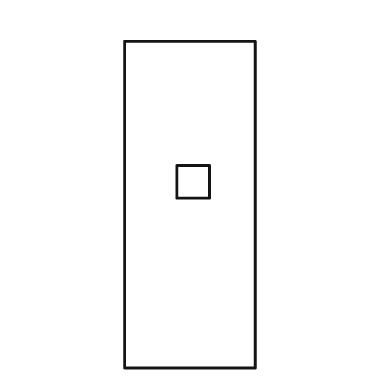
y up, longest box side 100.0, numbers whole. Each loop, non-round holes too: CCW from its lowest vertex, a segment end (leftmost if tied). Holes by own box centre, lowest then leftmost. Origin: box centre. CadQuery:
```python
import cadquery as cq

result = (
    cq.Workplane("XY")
    .moveTo(-20.0, -50.0)
    .lineTo(20.0, -50.0)
    .lineTo(20.0, 50.0)
    .lineTo(-20.0, 50.0)
    .close()
    .moveTo(-4.0, 2.0)
    .lineTo(6.0, 2.0)
    .lineTo(6.0, 12.0)
    .lineTo(-4.0, 12.0)
    .close()
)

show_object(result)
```